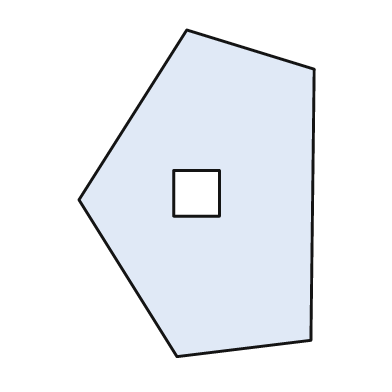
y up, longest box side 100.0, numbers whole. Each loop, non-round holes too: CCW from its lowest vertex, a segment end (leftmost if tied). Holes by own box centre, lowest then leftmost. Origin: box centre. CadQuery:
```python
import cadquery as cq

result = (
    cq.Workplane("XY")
    .moveTo(-6.0, -50.0)
    .lineTo(35.0, -45.0)
    .lineTo(36.0, 38.0)
    .lineTo(-3.0, 50.0)
    .lineTo(-36.0, -2.0)
    .close()
    .moveTo(-7.0, -7.0)
    .lineTo(7.0, -7.0)
    .lineTo(7.0, 7.0)
    .lineTo(-7.0, 7.0)
    .close()
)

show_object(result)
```